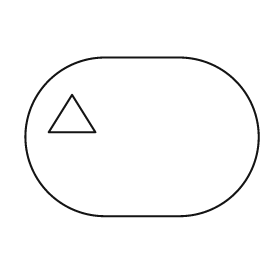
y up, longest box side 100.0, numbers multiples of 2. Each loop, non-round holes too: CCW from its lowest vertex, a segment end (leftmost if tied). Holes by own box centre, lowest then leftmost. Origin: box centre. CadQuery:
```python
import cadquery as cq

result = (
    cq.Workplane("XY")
    .moveTo(-16.0, -34.0)
    .lineTo(16.0, -34.0)
    .threePointArc((50.0, 0.0), (16.0, 34.0))
    .lineTo(-16.0, 34.0)
    .threePointArc((-50.0, 0.0), (-16.0, -34.0))
    .close()
    .moveTo(-40.0, 2.0)
    .lineTo(-20.0, 2.0)
    .lineTo(-30.0, 18.0)
    .close()
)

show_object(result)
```